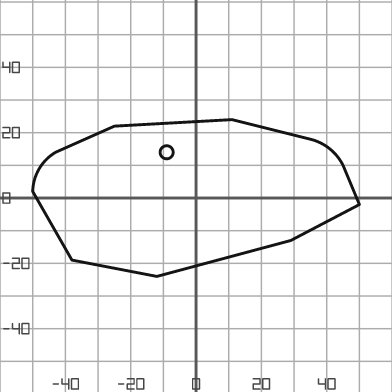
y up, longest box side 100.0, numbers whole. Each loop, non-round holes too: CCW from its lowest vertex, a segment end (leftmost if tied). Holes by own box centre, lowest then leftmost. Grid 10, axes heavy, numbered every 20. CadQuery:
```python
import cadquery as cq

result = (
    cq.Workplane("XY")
    .moveTo(-12.0, -24.0)
    .lineTo(29.0, -13.0)
    .lineTo(50.0, -2.0)
    .lineTo(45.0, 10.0)
    .threePointArc((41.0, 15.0), (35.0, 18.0))
    .lineTo(11.0, 24.0)
    .lineTo(-25.0, 22.0)
    .lineTo(-43.0, 14.0)
    .threePointArc((-48.0, 9.0), (-50.0, 2.0))
    .lineTo(-38.0, -19.0)
    .close()
    .moveTo(-9.0, 14.0)
    .circle(2.0)
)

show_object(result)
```